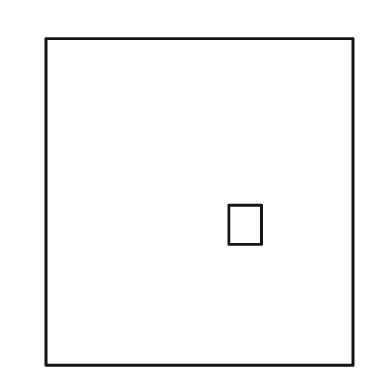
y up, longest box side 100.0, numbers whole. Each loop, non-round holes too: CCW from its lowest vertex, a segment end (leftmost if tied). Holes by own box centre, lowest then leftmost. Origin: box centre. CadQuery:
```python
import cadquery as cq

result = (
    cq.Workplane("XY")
    .moveTo(-47.0, -50.0)
    .lineTo(47.0, -50.0)
    .lineTo(47.0, 50.0)
    .lineTo(-47.0, 50.0)
    .close()
    .moveTo(9.0, -13.0)
    .lineTo(19.0, -13.0)
    .lineTo(19.0, -1.0)
    .lineTo(9.0, -1.0)
    .close()
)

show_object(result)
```